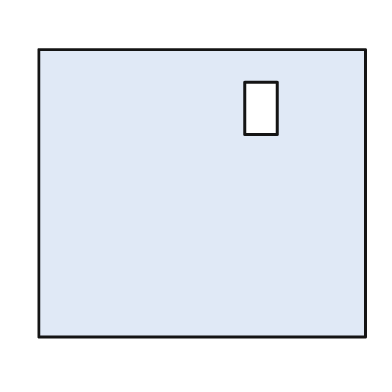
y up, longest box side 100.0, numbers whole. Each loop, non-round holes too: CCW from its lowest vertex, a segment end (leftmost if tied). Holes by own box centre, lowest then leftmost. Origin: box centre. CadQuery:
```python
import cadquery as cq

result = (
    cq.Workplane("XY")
    .moveTo(-50.0, -44.0)
    .lineTo(50.0, -44.0)
    .lineTo(50.0, 44.0)
    .lineTo(-50.0, 44.0)
    .close()
    .moveTo(13.0, 18.0)
    .lineTo(23.0, 18.0)
    .lineTo(23.0, 34.0)
    .lineTo(13.0, 34.0)
    .close()
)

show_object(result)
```